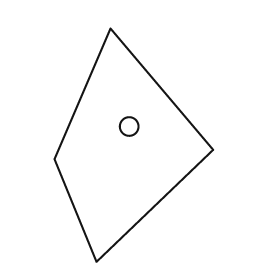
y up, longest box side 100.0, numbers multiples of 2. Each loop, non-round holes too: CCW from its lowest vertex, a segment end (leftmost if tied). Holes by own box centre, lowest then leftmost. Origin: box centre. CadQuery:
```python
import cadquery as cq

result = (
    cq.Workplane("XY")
    .moveTo(-16.0, -50.0)
    .lineTo(34.0, -2.0)
    .lineTo(-10.0, 50.0)
    .lineTo(-34.0, -6.0)
    .close()
    .moveTo(-2.0, 8.0)
    .circle(4.0)
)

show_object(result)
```